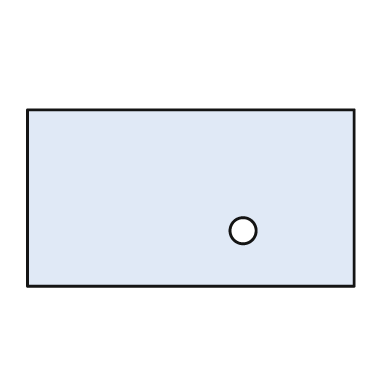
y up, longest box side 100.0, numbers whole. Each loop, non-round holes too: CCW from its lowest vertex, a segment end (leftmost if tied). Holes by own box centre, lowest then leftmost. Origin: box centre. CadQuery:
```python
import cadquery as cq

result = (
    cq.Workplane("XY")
    .moveTo(-50.0, -27.0)
    .lineTo(50.0, -27.0)
    .lineTo(50.0, 27.0)
    .lineTo(-50.0, 27.0)
    .close()
    .moveTo(16.0, -10.0)
    .circle(4.0)
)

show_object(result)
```